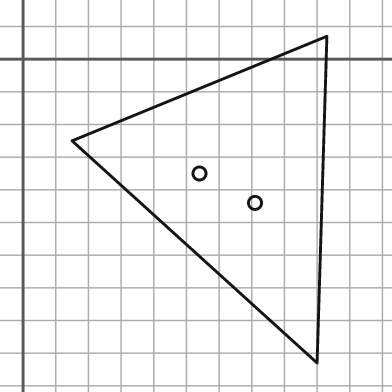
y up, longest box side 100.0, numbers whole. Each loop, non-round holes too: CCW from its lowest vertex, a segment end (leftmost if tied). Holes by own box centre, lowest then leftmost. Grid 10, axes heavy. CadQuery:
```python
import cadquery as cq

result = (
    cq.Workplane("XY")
    .moveTo(90.0, -93.0)
    .lineTo(93.0, 7.0)
    .lineTo(15.0, -25.0)
    .close()
    .moveTo(71.0, -44.0)
    .circle(2.0)
    .moveTo(54.0, -35.0)
    .circle(2.0)
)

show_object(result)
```